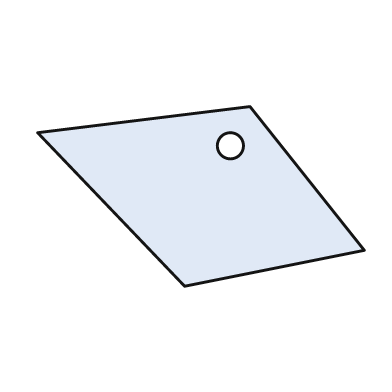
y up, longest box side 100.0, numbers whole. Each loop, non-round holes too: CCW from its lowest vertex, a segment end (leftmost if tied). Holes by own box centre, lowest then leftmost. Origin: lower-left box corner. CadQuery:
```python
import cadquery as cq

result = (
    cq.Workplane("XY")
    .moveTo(45.0, 0.0)
    .lineTo(100.0, 11.0)
    .lineTo(65.0, 55.0)
    .lineTo(0.0, 47.0)
    .close()
    .moveTo(59.0, 43.0)
    .circle(4.0)
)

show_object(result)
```